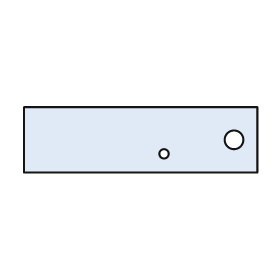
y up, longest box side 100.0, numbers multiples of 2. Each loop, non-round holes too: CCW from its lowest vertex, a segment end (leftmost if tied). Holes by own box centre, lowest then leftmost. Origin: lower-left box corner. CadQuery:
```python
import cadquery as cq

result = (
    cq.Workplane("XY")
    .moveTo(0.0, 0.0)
    .lineTo(100.0, 0.0)
    .lineTo(100.0, 28.0)
    .lineTo(0.0, 28.0)
    .close()
    .moveTo(60.0, 8.0)
    .circle(2.0)
    .moveTo(90.0, 14.0)
    .circle(4.0)
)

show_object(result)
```